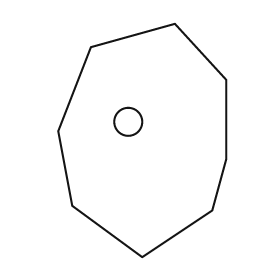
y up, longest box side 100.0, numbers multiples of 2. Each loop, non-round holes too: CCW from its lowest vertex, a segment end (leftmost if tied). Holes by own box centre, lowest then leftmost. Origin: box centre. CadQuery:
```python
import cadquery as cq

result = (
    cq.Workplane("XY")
    .moveTo(0.0, -50.0)
    .lineTo(30.0, -30.0)
    .lineTo(36.0, -8.0)
    .lineTo(36.0, 26.0)
    .lineTo(14.0, 50.0)
    .lineTo(-22.0, 40.0)
    .lineTo(-36.0, 4.0)
    .lineTo(-30.0, -28.0)
    .close()
    .moveTo(-6.0, 8.0)
    .circle(6.0)
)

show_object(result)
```